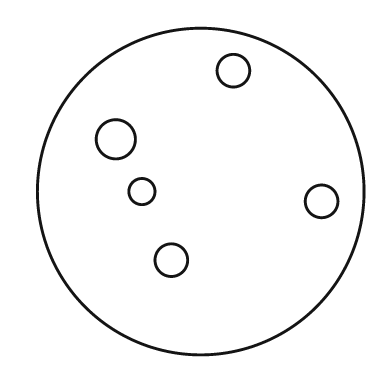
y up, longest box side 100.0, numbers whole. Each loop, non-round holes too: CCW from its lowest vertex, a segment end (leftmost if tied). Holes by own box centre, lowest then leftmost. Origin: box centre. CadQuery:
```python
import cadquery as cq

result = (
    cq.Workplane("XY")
    .moveTo(0.0, 0.0)
    .circle(50.0)
    .moveTo(-9.0, -21.0)
    .circle(5.0)
    .moveTo(37.0, -3.0)
    .circle(5.0)
    .moveTo(-18.0, 0.0)
    .circle(4.0)
    .moveTo(-26.0, 16.0)
    .circle(6.0)
    .moveTo(10.0, 37.0)
    .circle(5.0)
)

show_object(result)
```